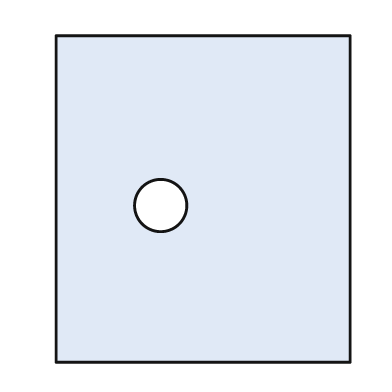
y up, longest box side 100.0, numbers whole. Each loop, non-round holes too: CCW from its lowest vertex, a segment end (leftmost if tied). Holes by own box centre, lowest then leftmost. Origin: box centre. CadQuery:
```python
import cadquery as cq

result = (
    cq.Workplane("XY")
    .moveTo(-45.0, -50.0)
    .lineTo(45.0, -50.0)
    .lineTo(45.0, 50.0)
    .lineTo(-45.0, 50.0)
    .close()
    .moveTo(-13.0, -2.0)
    .circle(8.0)
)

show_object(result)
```